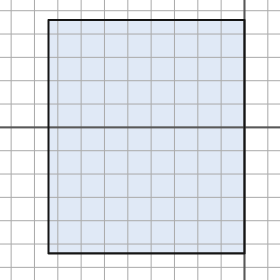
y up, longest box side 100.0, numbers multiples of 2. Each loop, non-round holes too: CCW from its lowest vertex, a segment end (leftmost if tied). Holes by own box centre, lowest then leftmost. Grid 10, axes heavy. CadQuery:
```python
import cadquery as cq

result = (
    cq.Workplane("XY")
    .moveTo(-84.0, -54.0)
    .lineTo(0.0, -54.0)
    .lineTo(0.0, 46.0)
    .lineTo(-84.0, 46.0)
    .close()
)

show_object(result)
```